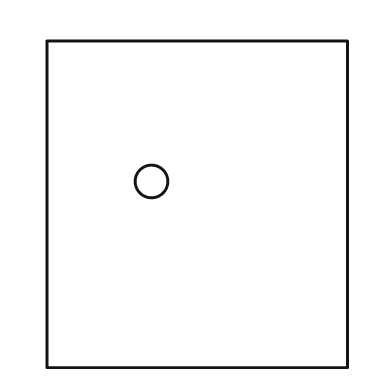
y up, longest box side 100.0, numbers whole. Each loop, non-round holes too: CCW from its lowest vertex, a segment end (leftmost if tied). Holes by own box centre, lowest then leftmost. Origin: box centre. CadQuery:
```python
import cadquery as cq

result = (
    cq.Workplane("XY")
    .moveTo(-46.0, -50.0)
    .lineTo(46.0, -50.0)
    .lineTo(46.0, 50.0)
    .lineTo(-46.0, 50.0)
    .close()
    .moveTo(-14.0, 7.0)
    .circle(5.0)
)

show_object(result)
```